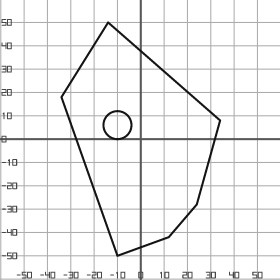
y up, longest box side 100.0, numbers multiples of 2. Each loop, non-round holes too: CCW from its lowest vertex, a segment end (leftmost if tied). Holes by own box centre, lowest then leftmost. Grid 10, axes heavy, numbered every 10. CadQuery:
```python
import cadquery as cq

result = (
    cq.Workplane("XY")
    .moveTo(-10.0, -50.0)
    .lineTo(12.0, -42.0)
    .lineTo(24.0, -28.0)
    .lineTo(34.0, 8.0)
    .lineTo(-14.0, 50.0)
    .lineTo(-34.0, 18.0)
    .close()
    .moveTo(-10.0, 6.0)
    .circle(6.0)
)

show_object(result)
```